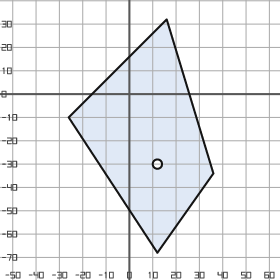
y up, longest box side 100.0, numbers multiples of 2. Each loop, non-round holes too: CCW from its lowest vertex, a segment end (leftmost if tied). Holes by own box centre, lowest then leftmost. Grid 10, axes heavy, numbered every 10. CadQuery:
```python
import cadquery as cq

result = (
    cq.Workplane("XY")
    .moveTo(12.0, -68.0)
    .lineTo(36.0, -34.0)
    .lineTo(16.0, 32.0)
    .lineTo(-26.0, -10.0)
    .close()
    .moveTo(12.0, -30.0)
    .circle(2.0)
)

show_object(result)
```